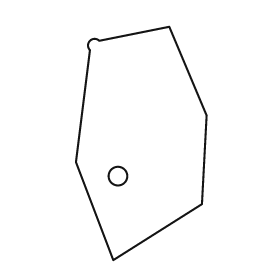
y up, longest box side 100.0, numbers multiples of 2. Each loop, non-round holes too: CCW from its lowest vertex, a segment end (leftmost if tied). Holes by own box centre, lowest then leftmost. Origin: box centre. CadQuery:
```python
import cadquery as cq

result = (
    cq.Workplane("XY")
    .moveTo(-12.0, -50.0)
    .lineTo(26.0, -26.0)
    .lineTo(28.0, 12.0)
    .lineTo(12.0, 50.0)
    .lineTo(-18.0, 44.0)
    .threePointArc((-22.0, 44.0), (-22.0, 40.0))
    .lineTo(-28.0, -8.0)
    .close()
    .moveTo(-10.0, -14.0)
    .circle(4.0)
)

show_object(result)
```